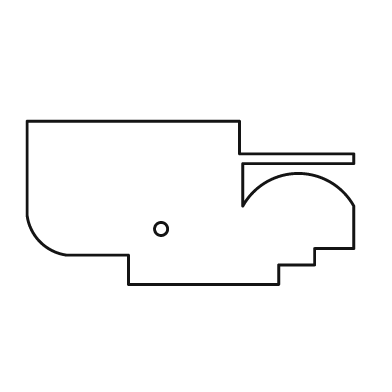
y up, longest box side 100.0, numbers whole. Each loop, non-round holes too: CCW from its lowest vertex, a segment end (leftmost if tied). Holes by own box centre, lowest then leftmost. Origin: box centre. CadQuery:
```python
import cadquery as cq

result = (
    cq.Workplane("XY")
    .moveTo(-19.0, -25.0)
    .lineTo(27.0, -25.0)
    .lineTo(27.0, -19.0)
    .lineTo(38.0, -19.0)
    .lineTo(38.0, -14.0)
    .lineTo(50.0, -14.0)
    .lineTo(50.0, -1.0)
    .threePointArc((33.0, 9.0), (16.0, -1.0))
    .lineTo(16.0, 12.0)
    .lineTo(50.0, 12.0)
    .lineTo(50.0, 15.0)
    .lineTo(15.0, 15.0)
    .lineTo(15.0, 25.0)
    .lineTo(-50.0, 25.0)
    .lineTo(-50.0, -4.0)
    .threePointArc((-46.0, -12.0), (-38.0, -16.0))
    .lineTo(-19.0, -16.0)
    .close()
    .moveTo(-9.0, -8.0)
    .circle(2.0)
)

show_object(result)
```